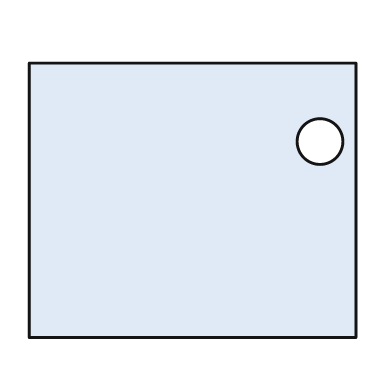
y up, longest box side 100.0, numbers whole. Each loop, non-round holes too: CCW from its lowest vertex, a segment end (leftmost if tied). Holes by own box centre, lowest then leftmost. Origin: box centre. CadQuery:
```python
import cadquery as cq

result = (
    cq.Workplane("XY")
    .moveTo(-50.0, -42.0)
    .lineTo(50.0, -42.0)
    .lineTo(50.0, 42.0)
    .lineTo(-50.0, 42.0)
    .close()
    .moveTo(39.0, 18.0)
    .circle(7.0)
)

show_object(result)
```